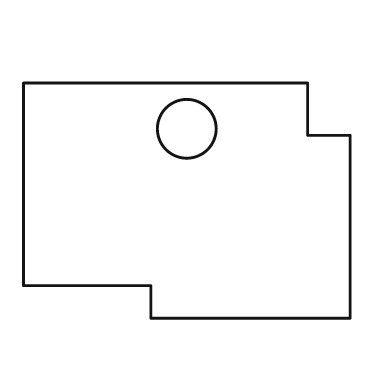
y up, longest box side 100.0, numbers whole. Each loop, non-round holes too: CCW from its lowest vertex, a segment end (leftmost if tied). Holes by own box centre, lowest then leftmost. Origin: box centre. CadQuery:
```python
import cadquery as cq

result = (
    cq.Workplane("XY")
    .moveTo(-11.0, -36.0)
    .lineTo(50.0, -36.0)
    .lineTo(50.0, 20.0)
    .lineTo(37.0, 20.0)
    .lineTo(37.0, 36.0)
    .lineTo(-50.0, 36.0)
    .lineTo(-50.0, -26.0)
    .lineTo(-11.0, -26.0)
    .close()
    .moveTo(0.0, 22.0)
    .circle(9.0)
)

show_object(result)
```